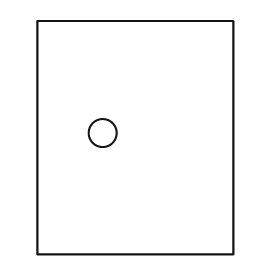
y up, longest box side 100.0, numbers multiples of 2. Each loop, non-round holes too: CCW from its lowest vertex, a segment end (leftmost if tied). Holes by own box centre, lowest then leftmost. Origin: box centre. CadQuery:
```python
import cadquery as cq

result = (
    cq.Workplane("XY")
    .moveTo(-42.0, -50.0)
    .lineTo(42.0, -50.0)
    .lineTo(42.0, 50.0)
    .lineTo(-42.0, 50.0)
    .close()
    .moveTo(-14.0, 2.0)
    .circle(6.0)
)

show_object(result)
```